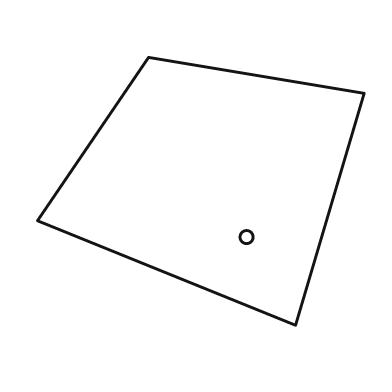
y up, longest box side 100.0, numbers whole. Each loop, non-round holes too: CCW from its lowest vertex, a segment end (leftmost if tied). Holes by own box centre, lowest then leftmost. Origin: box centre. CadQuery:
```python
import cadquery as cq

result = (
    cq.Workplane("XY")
    .moveTo(29.0, -41.0)
    .lineTo(50.0, 30.0)
    .lineTo(-16.0, 41.0)
    .lineTo(-50.0, -9.0)
    .close()
    .moveTo(14.0, -14.0)
    .circle(2.0)
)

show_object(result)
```